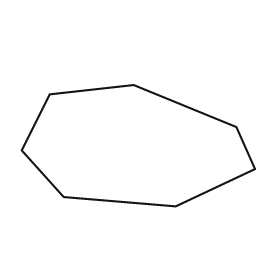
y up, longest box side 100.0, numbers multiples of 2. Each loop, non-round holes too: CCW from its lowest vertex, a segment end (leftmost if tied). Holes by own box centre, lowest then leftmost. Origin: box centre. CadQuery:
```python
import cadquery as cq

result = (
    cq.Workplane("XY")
    .moveTo(16.0, -26.0)
    .lineTo(50.0, -10.0)
    .lineTo(42.0, 8.0)
    .lineTo(-2.0, 26.0)
    .lineTo(-38.0, 22.0)
    .lineTo(-50.0, -2.0)
    .lineTo(-32.0, -22.0)
    .close()
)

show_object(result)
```